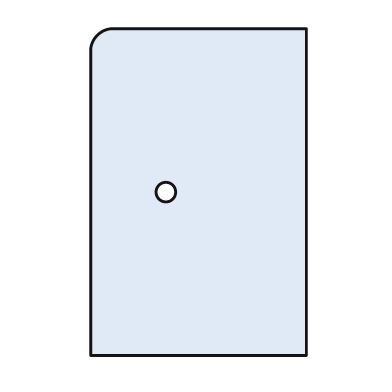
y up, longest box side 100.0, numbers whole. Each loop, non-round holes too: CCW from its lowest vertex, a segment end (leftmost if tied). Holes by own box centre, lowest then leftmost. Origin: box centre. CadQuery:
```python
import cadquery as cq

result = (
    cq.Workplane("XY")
    .moveTo(-33.0, -50.0)
    .lineTo(33.0, -50.0)
    .lineTo(33.0, 50.0)
    .lineTo(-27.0, 50.0)
    .threePointArc((-31.0, 48.0), (-33.0, 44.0))
    .close()
    .moveTo(-10.0, 0.0)
    .circle(3.0)
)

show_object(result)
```